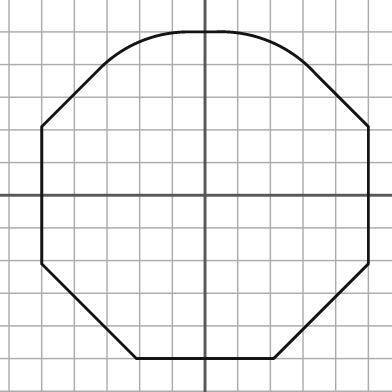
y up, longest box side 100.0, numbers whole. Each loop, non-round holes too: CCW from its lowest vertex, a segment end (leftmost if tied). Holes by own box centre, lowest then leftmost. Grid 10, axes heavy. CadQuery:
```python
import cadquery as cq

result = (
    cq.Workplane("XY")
    .moveTo(-21.0, -50.0)
    .lineTo(21.0, -50.0)
    .lineTo(50.0, -21.0)
    .lineTo(50.0, 21.0)
    .lineTo(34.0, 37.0)
    .threePointArc((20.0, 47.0), (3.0, 50.0))
    .lineTo(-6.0, 50.0)
    .threePointArc((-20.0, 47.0), (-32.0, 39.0))
    .lineTo(-50.0, 21.0)
    .lineTo(-50.0, -21.0)
    .close()
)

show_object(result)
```